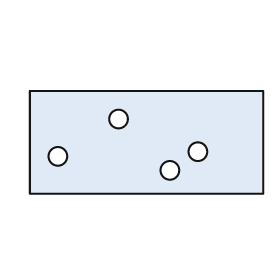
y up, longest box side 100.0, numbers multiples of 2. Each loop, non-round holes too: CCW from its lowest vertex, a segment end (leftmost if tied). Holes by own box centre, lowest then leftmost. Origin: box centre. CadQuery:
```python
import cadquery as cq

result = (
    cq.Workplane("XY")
    .moveTo(-50.0, -22.0)
    .lineTo(50.0, -22.0)
    .lineTo(50.0, 22.0)
    .lineTo(-50.0, 22.0)
    .close()
    .moveTo(10.0, -12.0)
    .circle(4.0)
    .moveTo(-38.0, -6.0)
    .circle(4.0)
    .moveTo(22.0, -4.0)
    .circle(4.0)
    .moveTo(-12.0, 10.0)
    .circle(4.0)
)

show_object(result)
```